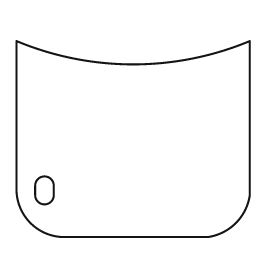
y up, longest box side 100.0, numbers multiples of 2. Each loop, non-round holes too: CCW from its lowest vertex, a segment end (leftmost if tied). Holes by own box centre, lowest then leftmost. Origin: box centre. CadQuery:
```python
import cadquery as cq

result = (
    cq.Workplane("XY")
    .moveTo(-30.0, -42.0)
    .lineTo(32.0, -42.0)
    .threePointArc((44.0, -36.0), (50.0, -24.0))
    .lineTo(50.0, 42.0)
    .threePointArc((0.0, 32.0), (-50.0, 42.0))
    .lineTo(-50.0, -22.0)
    .threePointArc((-44.0, -36.0), (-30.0, -42.0))
    .close()
    .moveTo(-42.0, -24.0)
    .threePointArc((-38.0, -28.0), (-34.0, -24.0))
    .lineTo(-34.0, -20.0)
    .threePointArc((-38.0, -16.0), (-42.0, -20.0))
    .close()
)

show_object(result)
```